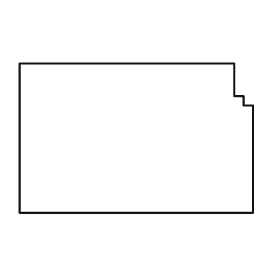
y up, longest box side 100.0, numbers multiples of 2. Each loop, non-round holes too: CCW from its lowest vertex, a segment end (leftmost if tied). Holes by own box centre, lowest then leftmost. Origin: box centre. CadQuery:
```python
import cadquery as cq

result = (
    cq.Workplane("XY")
    .moveTo(-50.0, -32.0)
    .lineTo(50.0, -32.0)
    .lineTo(50.0, 14.0)
    .lineTo(46.0, 14.0)
    .lineTo(46.0, 18.0)
    .lineTo(42.0, 18.0)
    .lineTo(42.0, 32.0)
    .lineTo(-50.0, 32.0)
    .close()
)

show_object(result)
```